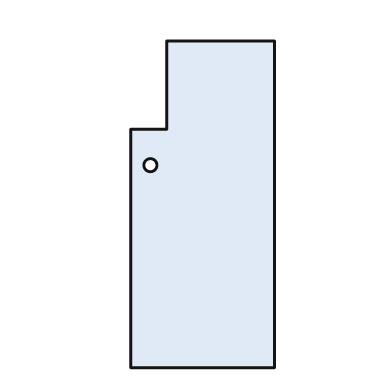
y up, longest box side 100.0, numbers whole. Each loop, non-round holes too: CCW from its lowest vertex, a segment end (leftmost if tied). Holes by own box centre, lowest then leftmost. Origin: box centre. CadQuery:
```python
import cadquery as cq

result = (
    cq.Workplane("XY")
    .moveTo(-22.0, -50.0)
    .lineTo(22.0, -50.0)
    .lineTo(22.0, 50.0)
    .lineTo(-11.0, 50.0)
    .lineTo(-11.0, 23.0)
    .lineTo(-22.0, 23.0)
    .close()
    .moveTo(-16.0, 12.0)
    .circle(2.0)
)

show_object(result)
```